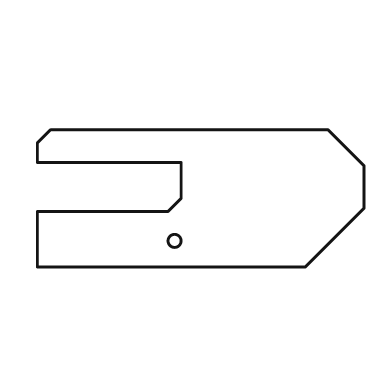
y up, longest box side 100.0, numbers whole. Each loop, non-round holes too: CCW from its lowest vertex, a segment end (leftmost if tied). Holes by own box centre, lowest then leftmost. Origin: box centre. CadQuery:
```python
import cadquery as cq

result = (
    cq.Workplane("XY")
    .moveTo(-50.0, -21.0)
    .lineTo(32.0, -21.0)
    .lineTo(50.0, -3.0)
    .lineTo(50.0, 10.0)
    .lineTo(39.0, 21.0)
    .lineTo(-46.0, 21.0)
    .lineTo(-50.0, 17.0)
    .lineTo(-50.0, 11.0)
    .lineTo(-6.0, 11.0)
    .lineTo(-6.0, 0.0)
    .lineTo(-10.0, -4.0)
    .lineTo(-50.0, -4.0)
    .close()
    .moveTo(-8.0, -13.0)
    .circle(2.0)
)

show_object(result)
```